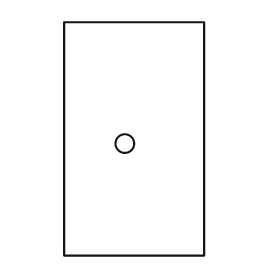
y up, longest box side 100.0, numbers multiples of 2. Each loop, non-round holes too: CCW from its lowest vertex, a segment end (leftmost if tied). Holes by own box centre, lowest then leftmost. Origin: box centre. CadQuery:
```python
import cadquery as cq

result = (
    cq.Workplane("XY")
    .moveTo(-30.0, -50.0)
    .lineTo(30.0, -50.0)
    .lineTo(30.0, 50.0)
    .lineTo(-30.0, 50.0)
    .close()
    .moveTo(-4.0, -2.0)
    .circle(4.0)
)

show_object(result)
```